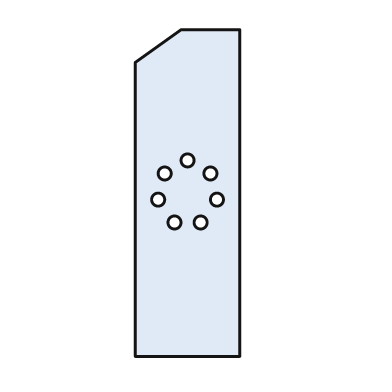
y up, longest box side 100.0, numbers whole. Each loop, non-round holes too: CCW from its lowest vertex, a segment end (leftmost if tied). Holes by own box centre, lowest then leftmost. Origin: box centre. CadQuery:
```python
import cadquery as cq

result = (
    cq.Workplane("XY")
    .moveTo(-16.0, -50.0)
    .lineTo(16.0, -50.0)
    .lineTo(16.0, 50.0)
    .lineTo(-2.0, 50.0)
    .lineTo(-16.0, 40.0)
    .close()
    .moveTo(-4.0, -9.0)
    .circle(2.0)
    .moveTo(4.0, -9.0)
    .circle(2.0)
    .moveTo(-9.0, -2.0)
    .circle(2.0)
    .moveTo(9.0, -2.0)
    .circle(2.0)
    .moveTo(-7.0, 6.0)
    .circle(2.0)
    .moveTo(7.0, 6.0)
    .circle(2.0)
    .moveTo(0.0, 10.0)
    .circle(2.0)
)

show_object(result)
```